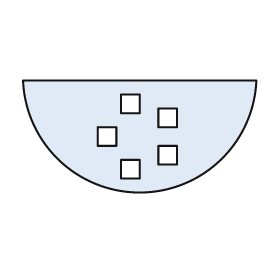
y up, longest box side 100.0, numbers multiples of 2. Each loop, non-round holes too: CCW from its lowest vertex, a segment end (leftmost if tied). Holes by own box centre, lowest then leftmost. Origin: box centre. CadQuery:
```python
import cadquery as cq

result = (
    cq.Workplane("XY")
    .moveTo(-50.0, 24.0)
    .threePointArc((0.0, -24.0), (50.0, 24.0))
    .close()
    .moveTo(-8.0, -18.0)
    .lineTo(0.0, -18.0)
    .lineTo(0.0, -10.0)
    .lineTo(-8.0, -10.0)
    .close()
    .moveTo(8.0, -12.0)
    .lineTo(16.0, -12.0)
    .lineTo(16.0, -4.0)
    .lineTo(8.0, -4.0)
    .close()
    .moveTo(-18.0, -4.0)
    .lineTo(-10.0, -4.0)
    .lineTo(-10.0, 4.0)
    .lineTo(-18.0, 4.0)
    .close()
    .moveTo(8.0, 4.0)
    .lineTo(16.0, 4.0)
    .lineTo(16.0, 12.0)
    .lineTo(8.0, 12.0)
    .close()
    .moveTo(-8.0, 10.0)
    .lineTo(0.0, 10.0)
    .lineTo(0.0, 18.0)
    .lineTo(-8.0, 18.0)
    .close()
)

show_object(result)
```